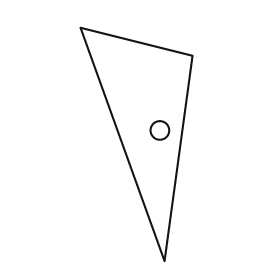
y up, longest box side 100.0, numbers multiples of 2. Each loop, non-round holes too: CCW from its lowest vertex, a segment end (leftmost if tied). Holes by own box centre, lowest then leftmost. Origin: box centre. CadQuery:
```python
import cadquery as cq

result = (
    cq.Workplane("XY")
    .moveTo(12.0, -50.0)
    .lineTo(24.0, 38.0)
    .lineTo(-24.0, 50.0)
    .close()
    .moveTo(10.0, 6.0)
    .circle(4.0)
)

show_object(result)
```